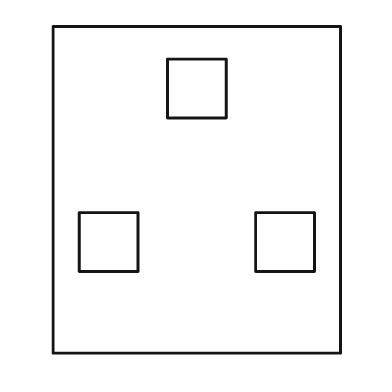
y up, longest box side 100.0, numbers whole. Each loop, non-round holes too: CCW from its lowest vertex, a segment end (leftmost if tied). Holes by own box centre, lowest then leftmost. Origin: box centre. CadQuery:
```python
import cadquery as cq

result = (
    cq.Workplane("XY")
    .moveTo(-44.0, -50.0)
    .lineTo(44.0, -50.0)
    .lineTo(44.0, 50.0)
    .lineTo(-44.0, 50.0)
    .close()
    .moveTo(-36.0, -25.0)
    .lineTo(-18.0, -25.0)
    .lineTo(-18.0, -7.0)
    .lineTo(-36.0, -7.0)
    .close()
    .moveTo(18.0, -25.0)
    .lineTo(36.0, -25.0)
    .lineTo(36.0, -7.0)
    .lineTo(18.0, -7.0)
    .close()
    .moveTo(-9.0, 22.0)
    .lineTo(9.0, 22.0)
    .lineTo(9.0, 40.0)
    .lineTo(-9.0, 40.0)
    .close()
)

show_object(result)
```